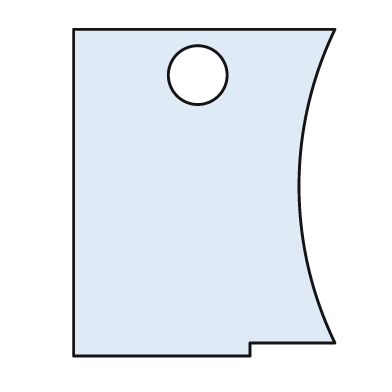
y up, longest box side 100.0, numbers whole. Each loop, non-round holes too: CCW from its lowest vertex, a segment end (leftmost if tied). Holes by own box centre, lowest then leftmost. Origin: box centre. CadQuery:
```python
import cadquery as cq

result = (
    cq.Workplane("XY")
    .moveTo(-40.0, -50.0)
    .lineTo(14.0, -50.0)
    .lineTo(14.0, -46.0)
    .lineTo(40.0, -46.0)
    .threePointArc((29.0, 2.0), (40.0, 50.0))
    .lineTo(-40.0, 50.0)
    .close()
    .moveTo(-2.0, 36.0)
    .circle(9.0)
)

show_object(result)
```